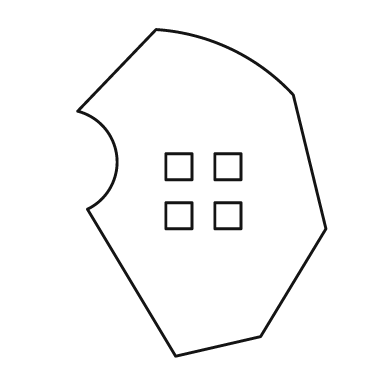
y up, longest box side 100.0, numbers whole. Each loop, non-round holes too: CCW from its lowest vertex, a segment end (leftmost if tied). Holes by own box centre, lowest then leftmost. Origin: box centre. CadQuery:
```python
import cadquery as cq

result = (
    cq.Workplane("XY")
    .moveTo(-8.0, -50.0)
    .lineTo(18.0, -44.0)
    .lineTo(38.0, -11.0)
    .lineTo(28.0, 30.0)
    .threePointArc((9.0, 44.0), (-14.0, 50.0))
    .lineTo(-38.0, 25.0)
    .threePointArc((-26.0, 11.0), (-35.0, -5.0))
    .close()
    .moveTo(-11.0, -11.0)
    .lineTo(-3.0, -11.0)
    .lineTo(-3.0, -3.0)
    .lineTo(-11.0, -3.0)
    .close()
    .moveTo(4.0, -11.0)
    .lineTo(12.0, -11.0)
    .lineTo(12.0, -3.0)
    .lineTo(4.0, -3.0)
    .close()
    .moveTo(-11.0, 4.0)
    .lineTo(-3.0, 4.0)
    .lineTo(-3.0, 12.0)
    .lineTo(-11.0, 12.0)
    .close()
    .moveTo(4.0, 4.0)
    .lineTo(12.0, 4.0)
    .lineTo(12.0, 12.0)
    .lineTo(4.0, 12.0)
    .close()
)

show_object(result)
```